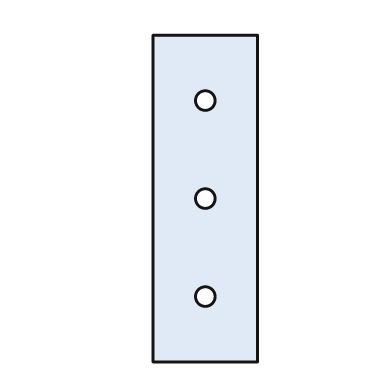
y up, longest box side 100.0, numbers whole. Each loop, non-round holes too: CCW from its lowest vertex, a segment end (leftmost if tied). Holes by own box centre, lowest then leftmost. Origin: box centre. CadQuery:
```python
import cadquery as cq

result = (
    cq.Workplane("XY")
    .moveTo(-16.0, -50.0)
    .lineTo(16.0, -50.0)
    .lineTo(16.0, 50.0)
    .lineTo(-16.0, 50.0)
    .close()
    .moveTo(0.0, -30.0)
    .circle(3.0)
    .moveTo(0.0, 0.0)
    .circle(3.0)
    .moveTo(0.0, 30.0)
    .circle(3.0)
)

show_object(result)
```